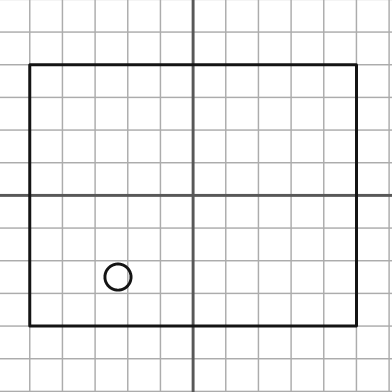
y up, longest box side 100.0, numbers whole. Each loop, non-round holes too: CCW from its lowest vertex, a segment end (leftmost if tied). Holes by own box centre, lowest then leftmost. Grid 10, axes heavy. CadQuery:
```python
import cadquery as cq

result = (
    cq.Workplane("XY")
    .moveTo(-50.0, -40.0)
    .lineTo(50.0, -40.0)
    .lineTo(50.0, 40.0)
    .lineTo(-50.0, 40.0)
    .close()
    .moveTo(-23.0, -25.0)
    .circle(4.0)
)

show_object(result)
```